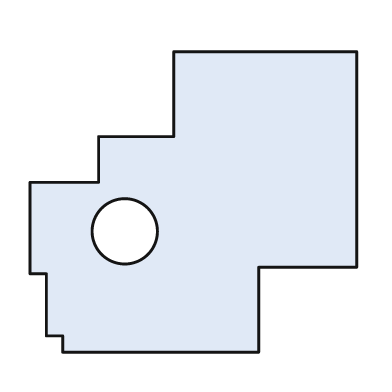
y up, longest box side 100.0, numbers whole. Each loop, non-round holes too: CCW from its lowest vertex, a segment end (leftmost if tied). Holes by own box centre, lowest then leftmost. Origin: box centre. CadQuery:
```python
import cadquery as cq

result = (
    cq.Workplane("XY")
    .moveTo(-40.0, -46.0)
    .lineTo(20.0, -46.0)
    .lineTo(20.0, -20.0)
    .lineTo(50.0, -20.0)
    .lineTo(50.0, 46.0)
    .lineTo(-6.0, 46.0)
    .lineTo(-6.0, 20.0)
    .lineTo(-29.0, 20.0)
    .lineTo(-29.0, 6.0)
    .lineTo(-50.0, 6.0)
    .lineTo(-50.0, -22.0)
    .lineTo(-45.0, -22.0)
    .lineTo(-45.0, -41.0)
    .lineTo(-40.0, -41.0)
    .close()
    .moveTo(-21.0, -9.0)
    .circle(10.0)
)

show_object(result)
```